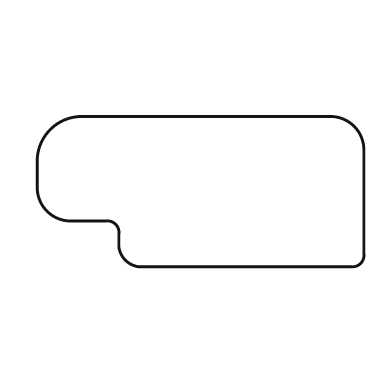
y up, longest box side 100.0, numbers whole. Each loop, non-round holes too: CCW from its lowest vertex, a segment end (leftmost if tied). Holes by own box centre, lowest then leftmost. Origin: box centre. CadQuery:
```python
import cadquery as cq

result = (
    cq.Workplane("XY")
    .moveTo(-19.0, -23.0)
    .lineTo(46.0, -23.0)
    .threePointArc((49.0, -22.0), (50.0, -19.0))
    .lineTo(50.0, 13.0)
    .threePointArc((47.0, 20.0), (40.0, 23.0))
    .lineTo(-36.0, 23.0)
    .threePointArc((-46.0, 19.0), (-50.0, 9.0))
    .lineTo(-50.0, 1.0)
    .threePointArc((-47.0, -6.0), (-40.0, -9.0))
    .lineTo(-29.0, -9.0)
    .threePointArc((-26.0, -10.0), (-25.0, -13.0))
    .lineTo(-25.0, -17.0)
    .threePointArc((-23.0, -21.0), (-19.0, -23.0))
    .close()
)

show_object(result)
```